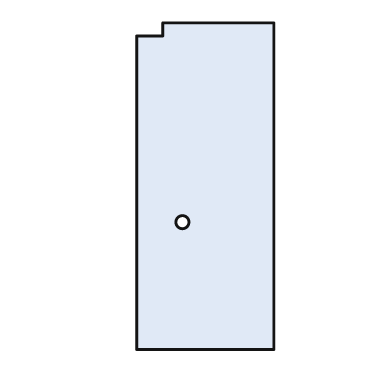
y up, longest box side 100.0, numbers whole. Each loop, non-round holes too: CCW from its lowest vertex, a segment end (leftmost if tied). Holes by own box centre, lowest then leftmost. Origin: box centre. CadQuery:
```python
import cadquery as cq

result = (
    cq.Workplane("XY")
    .moveTo(-21.0, -50.0)
    .lineTo(21.0, -50.0)
    .lineTo(21.0, 50.0)
    .lineTo(-13.0, 50.0)
    .lineTo(-13.0, 46.0)
    .lineTo(-21.0, 46.0)
    .close()
    .moveTo(-7.0, -11.0)
    .circle(2.0)
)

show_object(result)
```